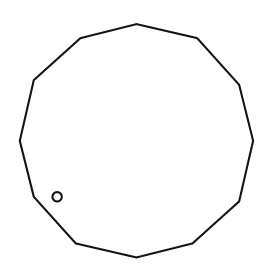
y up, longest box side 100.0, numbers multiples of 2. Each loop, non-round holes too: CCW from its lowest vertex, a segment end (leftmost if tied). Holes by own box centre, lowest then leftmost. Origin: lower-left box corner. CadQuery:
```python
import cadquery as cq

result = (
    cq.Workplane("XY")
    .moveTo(50.0, 0.0)
    .lineTo(74.0, 6.0)
    .lineTo(94.0, 24.0)
    .lineTo(100.0, 50.0)
    .lineTo(94.0, 74.0)
    .lineTo(76.0, 94.0)
    .lineTo(50.0, 100.0)
    .lineTo(26.0, 94.0)
    .lineTo(6.0, 76.0)
    .lineTo(0.0, 50.0)
    .lineTo(6.0, 26.0)
    .lineTo(24.0, 6.0)
    .close()
    .moveTo(16.0, 26.0)
    .circle(2.0)
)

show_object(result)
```